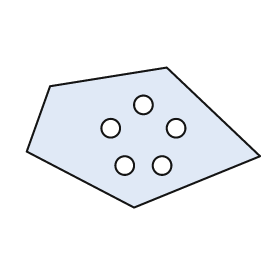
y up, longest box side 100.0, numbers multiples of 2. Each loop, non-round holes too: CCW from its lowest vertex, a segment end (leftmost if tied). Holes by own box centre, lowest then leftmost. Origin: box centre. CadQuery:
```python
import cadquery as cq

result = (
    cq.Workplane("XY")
    .moveTo(-4.0, -30.0)
    .lineTo(50.0, -8.0)
    .lineTo(10.0, 30.0)
    .lineTo(-40.0, 22.0)
    .lineTo(-50.0, -6.0)
    .close()
    .moveTo(-8.0, -12.0)
    .circle(4.0)
    .moveTo(8.0, -12.0)
    .circle(4.0)
    .moveTo(-14.0, 4.0)
    .circle(4.0)
    .moveTo(14.0, 4.0)
    .circle(4.0)
    .moveTo(0.0, 14.0)
    .circle(4.0)
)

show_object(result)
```